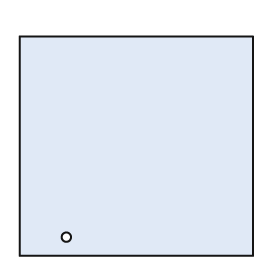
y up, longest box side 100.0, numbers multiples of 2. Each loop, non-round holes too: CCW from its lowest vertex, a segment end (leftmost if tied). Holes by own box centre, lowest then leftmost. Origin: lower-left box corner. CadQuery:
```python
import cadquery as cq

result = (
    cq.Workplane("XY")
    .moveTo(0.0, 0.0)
    .lineTo(100.0, 0.0)
    .lineTo(100.0, 94.0)
    .lineTo(0.0, 94.0)
    .close()
    .moveTo(20.0, 8.0)
    .circle(2.0)
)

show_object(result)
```